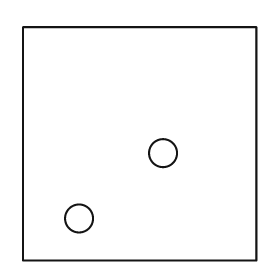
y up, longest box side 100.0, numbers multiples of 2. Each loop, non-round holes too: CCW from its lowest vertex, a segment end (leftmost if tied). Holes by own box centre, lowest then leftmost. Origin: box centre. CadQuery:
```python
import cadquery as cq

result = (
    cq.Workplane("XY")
    .moveTo(-50.0, -50.0)
    .lineTo(50.0, -50.0)
    .lineTo(50.0, 50.0)
    .lineTo(-50.0, 50.0)
    .close()
    .moveTo(-26.0, -32.0)
    .circle(6.0)
    .moveTo(10.0, -4.0)
    .circle(6.0)
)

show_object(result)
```